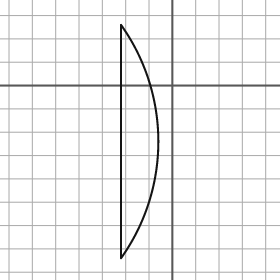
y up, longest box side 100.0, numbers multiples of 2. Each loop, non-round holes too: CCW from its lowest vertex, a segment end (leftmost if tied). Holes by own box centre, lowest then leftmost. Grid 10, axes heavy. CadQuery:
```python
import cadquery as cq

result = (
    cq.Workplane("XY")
    .moveTo(-22.0, -74.0)
    .threePointArc((-6.0, -24.0), (-22.0, 26.0))
    .close()
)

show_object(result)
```